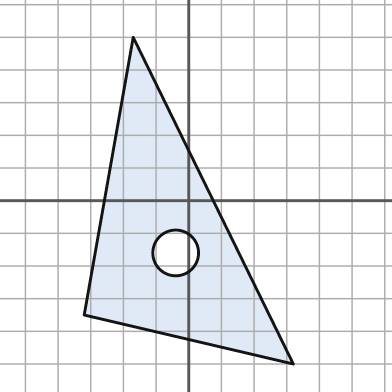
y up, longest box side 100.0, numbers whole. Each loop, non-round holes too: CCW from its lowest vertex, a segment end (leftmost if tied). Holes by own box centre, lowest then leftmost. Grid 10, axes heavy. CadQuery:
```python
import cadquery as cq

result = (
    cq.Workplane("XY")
    .moveTo(32.0, -50.0)
    .lineTo(-17.0, 50.0)
    .lineTo(-32.0, -35.0)
    .close()
    .moveTo(-4.0, -16.0)
    .circle(7.0)
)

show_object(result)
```